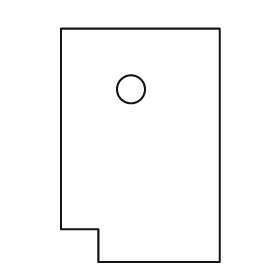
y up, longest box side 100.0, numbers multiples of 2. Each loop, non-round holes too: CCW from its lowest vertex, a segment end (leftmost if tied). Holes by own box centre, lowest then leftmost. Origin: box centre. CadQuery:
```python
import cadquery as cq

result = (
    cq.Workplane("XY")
    .moveTo(-18.0, -50.0)
    .lineTo(34.0, -50.0)
    .lineTo(34.0, 50.0)
    .lineTo(-34.0, 50.0)
    .lineTo(-34.0, -36.0)
    .lineTo(-18.0, -36.0)
    .close()
    .moveTo(-4.0, 24.0)
    .circle(6.0)
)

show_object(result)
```